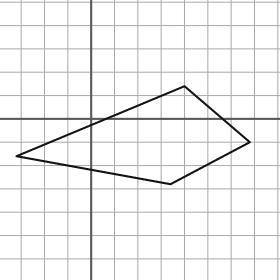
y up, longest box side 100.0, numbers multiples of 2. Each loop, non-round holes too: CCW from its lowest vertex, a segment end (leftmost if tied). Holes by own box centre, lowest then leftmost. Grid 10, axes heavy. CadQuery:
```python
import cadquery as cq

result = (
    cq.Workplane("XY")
    .moveTo(34.0, -28.0)
    .lineTo(68.0, -10.0)
    .lineTo(40.0, 14.0)
    .lineTo(-32.0, -16.0)
    .close()
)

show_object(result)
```